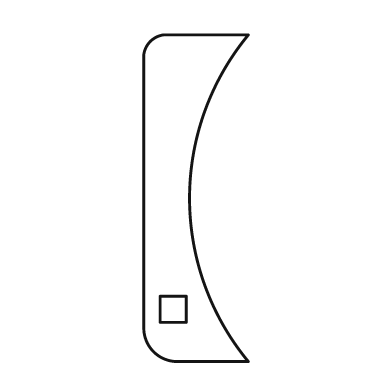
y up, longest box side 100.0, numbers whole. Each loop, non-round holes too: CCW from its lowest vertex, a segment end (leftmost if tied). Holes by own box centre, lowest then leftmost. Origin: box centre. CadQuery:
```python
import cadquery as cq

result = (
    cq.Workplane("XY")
    .moveTo(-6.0, -50.0)
    .lineTo(16.0, -50.0)
    .threePointArc((-2.0, 0.0), (16.0, 50.0))
    .lineTo(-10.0, 50.0)
    .threePointArc((-14.0, 48.0), (-16.0, 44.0))
    .lineTo(-16.0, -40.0)
    .threePointArc((-13.0, -47.0), (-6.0, -50.0))
    .close()
    .moveTo(-11.0, -38.0)
    .lineTo(-3.0, -38.0)
    .lineTo(-3.0, -30.0)
    .lineTo(-11.0, -30.0)
    .close()
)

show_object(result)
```